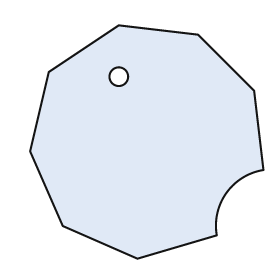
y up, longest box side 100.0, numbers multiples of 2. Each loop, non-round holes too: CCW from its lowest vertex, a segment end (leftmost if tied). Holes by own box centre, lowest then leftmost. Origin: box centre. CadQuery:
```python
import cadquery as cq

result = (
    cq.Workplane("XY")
    .moveTo(-4.0, -50.0)
    .lineTo(30.0, -40.0)
    .threePointArc((34.0, -22.0), (50.0, -12.0))
    .lineTo(46.0, 22.0)
    .lineTo(22.0, 46.0)
    .lineTo(-12.0, 50.0)
    .lineTo(-42.0, 30.0)
    .lineTo(-50.0, -4.0)
    .lineTo(-36.0, -36.0)
    .close()
    .moveTo(-12.0, 28.0)
    .circle(4.0)
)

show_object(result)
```